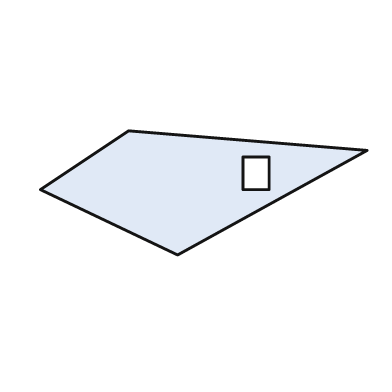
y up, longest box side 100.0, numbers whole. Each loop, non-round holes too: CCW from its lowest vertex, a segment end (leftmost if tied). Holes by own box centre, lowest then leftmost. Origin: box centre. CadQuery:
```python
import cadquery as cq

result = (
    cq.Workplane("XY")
    .moveTo(-8.0, -19.0)
    .lineTo(50.0, 13.0)
    .lineTo(-23.0, 19.0)
    .lineTo(-50.0, 1.0)
    .close()
    .moveTo(12.0, 1.0)
    .lineTo(20.0, 1.0)
    .lineTo(20.0, 11.0)
    .lineTo(12.0, 11.0)
    .close()
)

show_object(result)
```